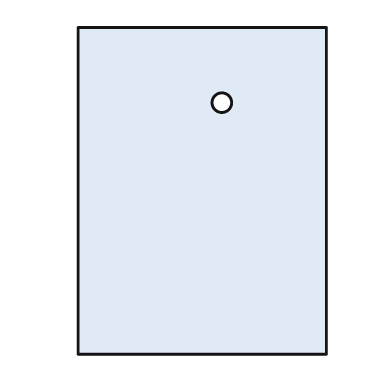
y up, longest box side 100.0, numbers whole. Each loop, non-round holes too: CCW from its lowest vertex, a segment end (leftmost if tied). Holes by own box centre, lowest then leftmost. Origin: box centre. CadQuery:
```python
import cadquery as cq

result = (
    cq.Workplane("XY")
    .moveTo(-38.0, -50.0)
    .lineTo(38.0, -50.0)
    .lineTo(38.0, 50.0)
    .lineTo(-38.0, 50.0)
    .close()
    .moveTo(6.0, 27.0)
    .circle(3.0)
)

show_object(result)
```